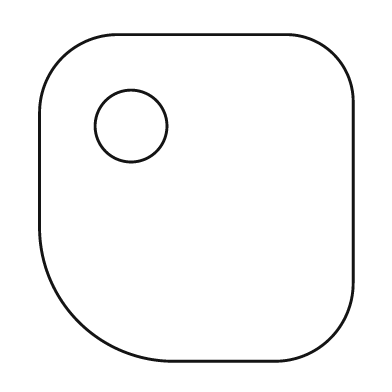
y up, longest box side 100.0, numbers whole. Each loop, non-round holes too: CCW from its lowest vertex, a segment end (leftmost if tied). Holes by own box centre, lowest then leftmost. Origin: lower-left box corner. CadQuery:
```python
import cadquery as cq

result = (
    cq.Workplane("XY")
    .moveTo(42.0, 0.0)
    .lineTo(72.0, 0.0)
    .threePointArc((89.0, 7.0), (96.0, 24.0))
    .lineTo(96.0, 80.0)
    .threePointArc((90.0, 94.0), (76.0, 100.0))
    .lineTo(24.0, 100.0)
    .threePointArc((7.0, 93.0), (0.0, 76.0))
    .lineTo(0.0, 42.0)
    .threePointArc((12.0, 12.0), (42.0, 0.0))
    .close()
    .moveTo(28.0, 72.0)
    .circle(11.0)
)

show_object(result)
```